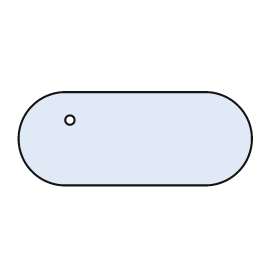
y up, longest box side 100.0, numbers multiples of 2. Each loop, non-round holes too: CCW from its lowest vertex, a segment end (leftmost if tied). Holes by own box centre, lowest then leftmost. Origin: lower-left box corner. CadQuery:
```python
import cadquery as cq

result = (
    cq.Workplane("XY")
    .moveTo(20.0, 0.0)
    .lineTo(80.0, 0.0)
    .threePointArc((100.0, 20.0), (80.0, 40.0))
    .lineTo(20.0, 40.0)
    .threePointArc((0.0, 20.0), (20.0, 0.0))
    .close()
    .moveTo(22.0, 28.0)
    .circle(2.0)
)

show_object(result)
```